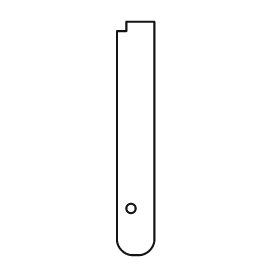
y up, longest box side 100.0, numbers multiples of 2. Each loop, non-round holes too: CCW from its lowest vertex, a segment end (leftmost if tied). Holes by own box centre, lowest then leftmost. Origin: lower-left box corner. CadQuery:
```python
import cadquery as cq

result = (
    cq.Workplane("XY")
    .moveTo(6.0, 0.0)
    .lineTo(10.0, 0.0)
    .threePointArc((14.0, 2.0), (16.0, 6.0))
    .lineTo(16.0, 100.0)
    .lineTo(4.0, 100.0)
    .lineTo(4.0, 96.0)
    .lineTo(0.0, 96.0)
    .lineTo(0.0, 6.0)
    .threePointArc((2.0, 2.0), (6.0, 0.0))
    .close()
    .moveTo(6.0, 20.0)
    .circle(2.0)
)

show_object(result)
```